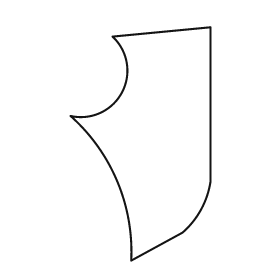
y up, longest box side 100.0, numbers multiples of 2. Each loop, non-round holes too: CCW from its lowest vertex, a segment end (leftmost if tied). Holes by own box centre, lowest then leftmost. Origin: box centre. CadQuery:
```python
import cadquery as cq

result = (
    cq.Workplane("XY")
    .moveTo(-4.0, -50.0)
    .lineTo(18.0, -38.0)
    .threePointArc((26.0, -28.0), (30.0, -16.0))
    .lineTo(30.0, 50.0)
    .lineTo(-12.0, 46.0)
    .threePointArc((-8.0, 22.0), (-30.0, 12.0))
    .threePointArc((-10.0, -16.0), (-4.0, -50.0))
    .close()
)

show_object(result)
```